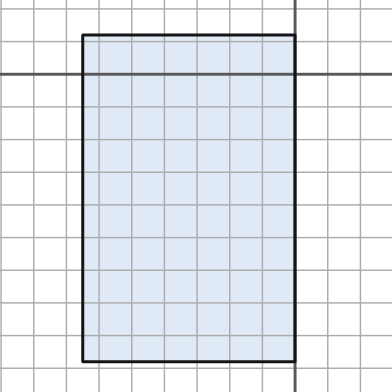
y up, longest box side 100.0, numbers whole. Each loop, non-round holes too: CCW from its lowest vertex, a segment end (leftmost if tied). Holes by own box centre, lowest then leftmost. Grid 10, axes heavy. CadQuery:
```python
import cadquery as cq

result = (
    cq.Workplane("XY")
    .moveTo(-65.0, -88.0)
    .lineTo(0.0, -88.0)
    .lineTo(0.0, 12.0)
    .lineTo(-65.0, 12.0)
    .close()
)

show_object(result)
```